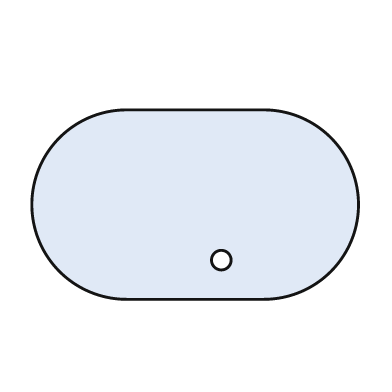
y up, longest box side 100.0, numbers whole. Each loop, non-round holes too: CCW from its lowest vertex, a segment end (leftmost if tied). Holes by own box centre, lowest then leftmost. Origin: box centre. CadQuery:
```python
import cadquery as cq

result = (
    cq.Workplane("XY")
    .moveTo(-21.0, -29.0)
    .lineTo(21.0, -29.0)
    .threePointArc((50.0, 0.0), (21.0, 29.0))
    .lineTo(-21.0, 29.0)
    .threePointArc((-50.0, 0.0), (-21.0, -29.0))
    .close()
    .moveTo(8.0, -17.0)
    .circle(3.0)
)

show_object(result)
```